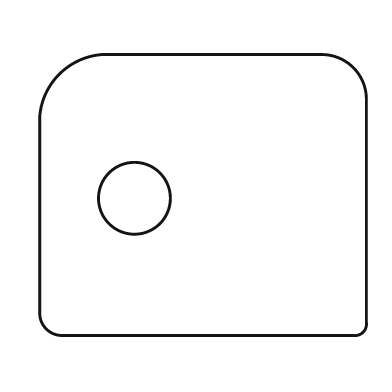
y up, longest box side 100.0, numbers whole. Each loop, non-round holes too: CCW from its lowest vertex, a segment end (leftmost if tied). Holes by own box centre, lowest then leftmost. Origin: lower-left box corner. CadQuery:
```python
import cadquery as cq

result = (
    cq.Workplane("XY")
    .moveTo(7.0, 0.0)
    .lineTo(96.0, 0.0)
    .threePointArc((99.0, 1.0), (100.0, 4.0))
    .lineTo(100.0, 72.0)
    .threePointArc((96.0, 82.0), (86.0, 86.0))
    .lineTo(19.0, 86.0)
    .threePointArc((6.0, 80.0), (0.0, 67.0))
    .lineTo(0.0, 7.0)
    .threePointArc((2.0, 2.0), (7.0, 0.0))
    .close()
    .moveTo(29.0, 42.0)
    .circle(11.0)
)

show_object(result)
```